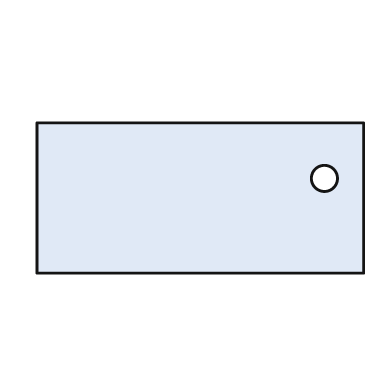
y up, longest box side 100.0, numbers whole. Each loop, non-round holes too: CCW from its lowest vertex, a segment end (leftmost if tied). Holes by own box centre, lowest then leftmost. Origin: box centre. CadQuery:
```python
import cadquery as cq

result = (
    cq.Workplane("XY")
    .moveTo(-50.0, -23.0)
    .lineTo(50.0, -23.0)
    .lineTo(50.0, 23.0)
    .lineTo(-50.0, 23.0)
    .close()
    .moveTo(38.0, 6.0)
    .circle(4.0)
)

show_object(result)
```